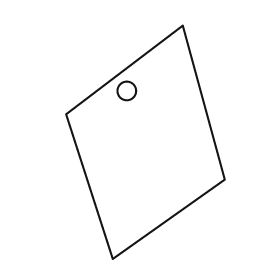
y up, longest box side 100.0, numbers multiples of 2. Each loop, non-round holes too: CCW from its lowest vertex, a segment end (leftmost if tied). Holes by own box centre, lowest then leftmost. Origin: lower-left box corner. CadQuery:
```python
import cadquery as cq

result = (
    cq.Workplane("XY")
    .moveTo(20.0, 0.0)
    .lineTo(68.0, 34.0)
    .lineTo(50.0, 100.0)
    .lineTo(0.0, 62.0)
    .close()
    .moveTo(26.0, 72.0)
    .circle(4.0)
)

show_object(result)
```